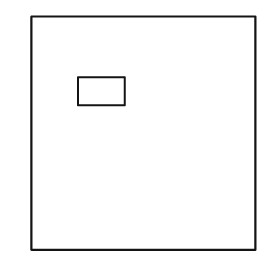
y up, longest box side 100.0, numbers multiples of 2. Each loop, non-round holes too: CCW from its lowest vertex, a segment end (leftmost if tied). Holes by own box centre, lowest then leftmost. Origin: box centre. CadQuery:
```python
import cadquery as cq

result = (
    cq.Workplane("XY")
    .moveTo(-48.0, -50.0)
    .lineTo(48.0, -50.0)
    .lineTo(48.0, 50.0)
    .lineTo(-48.0, 50.0)
    .close()
    .moveTo(-28.0, 12.0)
    .lineTo(-8.0, 12.0)
    .lineTo(-8.0, 24.0)
    .lineTo(-28.0, 24.0)
    .close()
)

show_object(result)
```